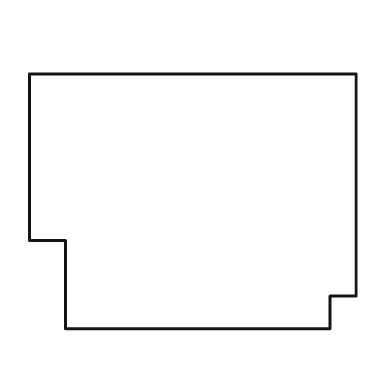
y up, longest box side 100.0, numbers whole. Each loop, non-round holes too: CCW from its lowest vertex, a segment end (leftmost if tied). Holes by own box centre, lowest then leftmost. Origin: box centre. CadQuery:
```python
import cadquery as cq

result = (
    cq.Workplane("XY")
    .moveTo(-39.0, -39.0)
    .lineTo(42.0, -39.0)
    .lineTo(42.0, -29.0)
    .lineTo(50.0, -29.0)
    .lineTo(50.0, 39.0)
    .lineTo(-50.0, 39.0)
    .lineTo(-50.0, -12.0)
    .lineTo(-39.0, -12.0)
    .close()
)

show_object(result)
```